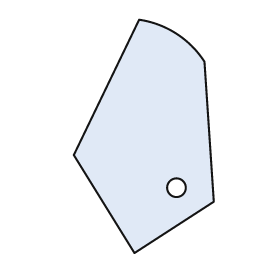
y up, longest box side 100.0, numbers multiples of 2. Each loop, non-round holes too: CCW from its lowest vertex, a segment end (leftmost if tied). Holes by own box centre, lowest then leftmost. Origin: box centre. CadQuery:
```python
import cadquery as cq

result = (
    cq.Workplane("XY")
    .moveTo(-4.0, -50.0)
    .lineTo(30.0, -28.0)
    .lineTo(26.0, 32.0)
    .threePointArc((14.0, 44.0), (-2.0, 50.0))
    .lineTo(-30.0, -8.0)
    .close()
    .moveTo(14.0, -22.0)
    .circle(4.0)
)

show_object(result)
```